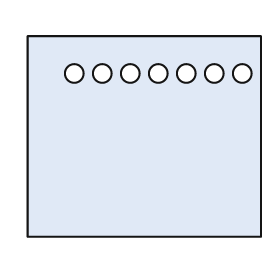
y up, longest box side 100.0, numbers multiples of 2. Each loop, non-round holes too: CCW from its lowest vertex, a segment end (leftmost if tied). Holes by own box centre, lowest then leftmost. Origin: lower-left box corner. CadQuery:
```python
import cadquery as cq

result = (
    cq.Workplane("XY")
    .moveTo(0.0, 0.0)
    .lineTo(100.0, 0.0)
    .lineTo(100.0, 86.0)
    .lineTo(0.0, 86.0)
    .close()
    .moveTo(20.0, 70.0)
    .circle(4.0)
    .moveTo(32.0, 70.0)
    .circle(4.0)
    .moveTo(44.0, 70.0)
    .circle(4.0)
    .moveTo(56.0, 70.0)
    .circle(4.0)
    .moveTo(68.0, 70.0)
    .circle(4.0)
    .moveTo(80.0, 70.0)
    .circle(4.0)
    .moveTo(92.0, 70.0)
    .circle(4.0)
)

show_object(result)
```